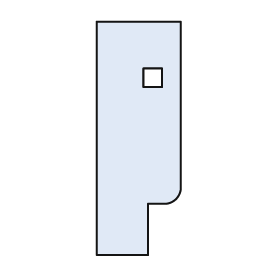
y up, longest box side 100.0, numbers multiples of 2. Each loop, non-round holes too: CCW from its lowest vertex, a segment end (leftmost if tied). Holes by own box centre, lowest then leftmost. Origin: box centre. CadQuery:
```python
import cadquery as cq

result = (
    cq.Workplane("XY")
    .moveTo(-18.0, -50.0)
    .lineTo(4.0, -50.0)
    .lineTo(4.0, -28.0)
    .lineTo(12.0, -28.0)
    .threePointArc((16.0, -26.0), (18.0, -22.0))
    .lineTo(18.0, 50.0)
    .lineTo(-18.0, 50.0)
    .close()
    .moveTo(2.0, 22.0)
    .lineTo(10.0, 22.0)
    .lineTo(10.0, 30.0)
    .lineTo(2.0, 30.0)
    .close()
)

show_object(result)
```